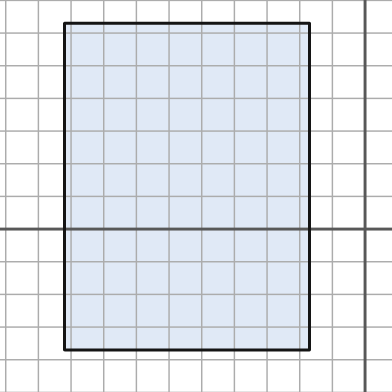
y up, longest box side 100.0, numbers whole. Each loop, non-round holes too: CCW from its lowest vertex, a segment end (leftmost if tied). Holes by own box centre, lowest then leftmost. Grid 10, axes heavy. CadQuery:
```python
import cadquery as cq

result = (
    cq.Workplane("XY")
    .moveTo(-92.0, -37.0)
    .lineTo(-17.0, -37.0)
    .lineTo(-17.0, 63.0)
    .lineTo(-92.0, 63.0)
    .close()
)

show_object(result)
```